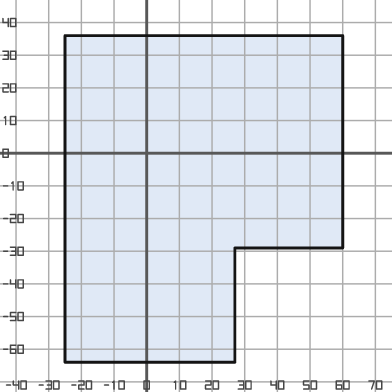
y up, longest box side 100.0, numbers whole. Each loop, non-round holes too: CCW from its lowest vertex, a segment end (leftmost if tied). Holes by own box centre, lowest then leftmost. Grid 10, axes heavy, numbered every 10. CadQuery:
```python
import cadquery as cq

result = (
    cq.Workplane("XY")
    .moveTo(-25.0, -64.0)
    .lineTo(27.0, -64.0)
    .lineTo(27.0, -29.0)
    .lineTo(60.0, -29.0)
    .lineTo(60.0, 36.0)
    .lineTo(-25.0, 36.0)
    .close()
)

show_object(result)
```